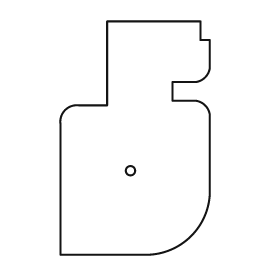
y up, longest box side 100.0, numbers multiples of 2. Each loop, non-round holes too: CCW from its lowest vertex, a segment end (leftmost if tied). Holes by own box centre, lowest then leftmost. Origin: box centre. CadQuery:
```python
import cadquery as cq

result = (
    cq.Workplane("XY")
    .moveTo(-32.0, -50.0)
    .lineTo(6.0, -50.0)
    .threePointArc((24.0, -42.0), (32.0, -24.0))
    .lineTo(32.0, 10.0)
    .threePointArc((30.0, 14.0), (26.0, 16.0))
    .lineTo(16.0, 16.0)
    .lineTo(16.0, 24.0)
    .lineTo(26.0, 24.0)
    .threePointArc((30.0, 26.0), (32.0, 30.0))
    .lineTo(32.0, 42.0)
    .lineTo(28.0, 42.0)
    .lineTo(28.0, 50.0)
    .lineTo(-12.0, 50.0)
    .lineTo(-12.0, 14.0)
    .lineTo(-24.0, 14.0)
    .threePointArc((-30.0, 12.0), (-32.0, 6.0))
    .close()
    .moveTo(-2.0, -14.0)
    .circle(2.0)
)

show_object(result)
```